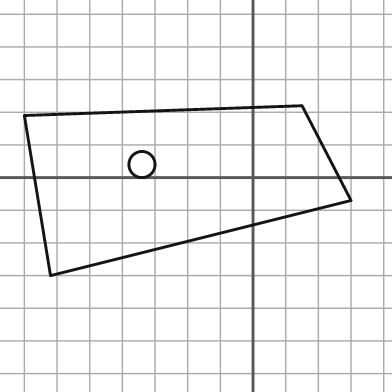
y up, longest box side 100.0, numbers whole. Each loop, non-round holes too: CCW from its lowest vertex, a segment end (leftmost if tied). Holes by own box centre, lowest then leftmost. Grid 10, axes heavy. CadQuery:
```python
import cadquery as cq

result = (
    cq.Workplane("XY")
    .moveTo(-62.0, -30.0)
    .lineTo(30.0, -7.0)
    .lineTo(15.0, 22.0)
    .lineTo(-70.0, 19.0)
    .close()
    .moveTo(-34.0, 4.0)
    .circle(4.0)
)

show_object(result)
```